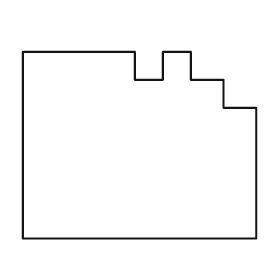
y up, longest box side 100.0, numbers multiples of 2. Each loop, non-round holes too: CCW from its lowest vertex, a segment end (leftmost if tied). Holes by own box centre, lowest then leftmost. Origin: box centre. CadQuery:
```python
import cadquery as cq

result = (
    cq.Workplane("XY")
    .moveTo(-50.0, -40.0)
    .lineTo(50.0, -40.0)
    .lineTo(50.0, 16.0)
    .lineTo(36.0, 16.0)
    .lineTo(36.0, 28.0)
    .lineTo(22.0, 28.0)
    .lineTo(22.0, 40.0)
    .lineTo(10.0, 40.0)
    .lineTo(10.0, 28.0)
    .lineTo(-2.0, 28.0)
    .lineTo(-2.0, 40.0)
    .lineTo(-50.0, 40.0)
    .close()
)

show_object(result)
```